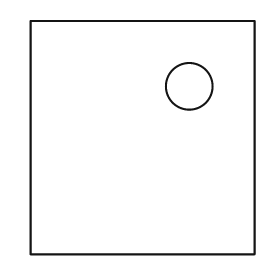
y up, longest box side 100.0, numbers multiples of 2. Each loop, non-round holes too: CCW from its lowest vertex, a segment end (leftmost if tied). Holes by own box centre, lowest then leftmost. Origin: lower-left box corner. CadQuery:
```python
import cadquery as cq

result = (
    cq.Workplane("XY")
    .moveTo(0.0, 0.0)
    .lineTo(96.0, 0.0)
    .lineTo(96.0, 100.0)
    .lineTo(0.0, 100.0)
    .close()
    .moveTo(68.0, 72.0)
    .circle(10.0)
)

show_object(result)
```